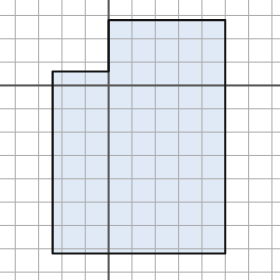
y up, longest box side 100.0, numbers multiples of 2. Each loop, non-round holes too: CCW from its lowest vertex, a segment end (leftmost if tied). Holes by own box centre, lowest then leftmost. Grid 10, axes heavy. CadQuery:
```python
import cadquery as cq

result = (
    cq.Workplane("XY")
    .moveTo(-24.0, -72.0)
    .lineTo(50.0, -72.0)
    .lineTo(50.0, 28.0)
    .lineTo(0.0, 28.0)
    .lineTo(0.0, 6.0)
    .lineTo(-24.0, 6.0)
    .close()
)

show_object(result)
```